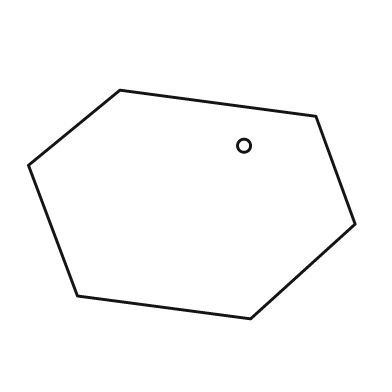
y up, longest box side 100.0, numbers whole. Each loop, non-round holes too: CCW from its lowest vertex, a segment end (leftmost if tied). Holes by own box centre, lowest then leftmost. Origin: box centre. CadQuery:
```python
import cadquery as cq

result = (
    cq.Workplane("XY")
    .moveTo(18.0, -35.0)
    .lineTo(50.0, -6.0)
    .lineTo(38.0, 27.0)
    .lineTo(-22.0, 35.0)
    .lineTo(-50.0, 12.0)
    .lineTo(-35.0, -28.0)
    .close()
    .moveTo(16.0, 18.0)
    .circle(2.0)
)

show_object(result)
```